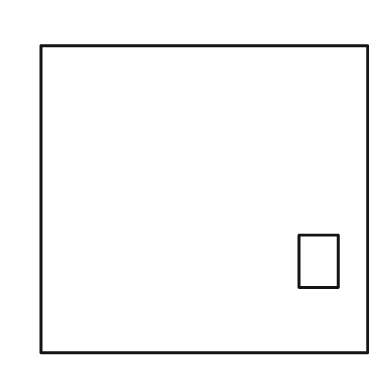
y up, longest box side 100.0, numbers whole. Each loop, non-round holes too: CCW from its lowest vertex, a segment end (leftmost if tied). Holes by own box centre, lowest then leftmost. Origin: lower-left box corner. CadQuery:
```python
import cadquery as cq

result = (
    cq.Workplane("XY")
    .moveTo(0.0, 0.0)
    .lineTo(100.0, 0.0)
    .lineTo(100.0, 94.0)
    .lineTo(0.0, 94.0)
    .close()
    .moveTo(79.0, 20.0)
    .lineTo(91.0, 20.0)
    .lineTo(91.0, 36.0)
    .lineTo(79.0, 36.0)
    .close()
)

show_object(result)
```